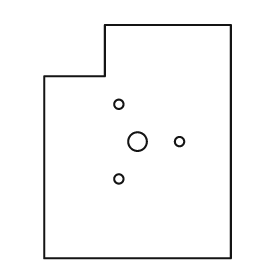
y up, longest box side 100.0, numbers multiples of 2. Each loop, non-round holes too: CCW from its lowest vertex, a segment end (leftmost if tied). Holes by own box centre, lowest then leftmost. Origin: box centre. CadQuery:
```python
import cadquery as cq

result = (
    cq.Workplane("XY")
    .moveTo(-40.0, -50.0)
    .lineTo(40.0, -50.0)
    .lineTo(40.0, 50.0)
    .lineTo(-14.0, 50.0)
    .lineTo(-14.0, 28.0)
    .lineTo(-40.0, 28.0)
    .close()
    .moveTo(-8.0, -16.0)
    .circle(2.0)
    .moveTo(0.0, 0.0)
    .circle(4.0)
    .moveTo(18.0, 0.0)
    .circle(2.0)
    .moveTo(-8.0, 16.0)
    .circle(2.0)
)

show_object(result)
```